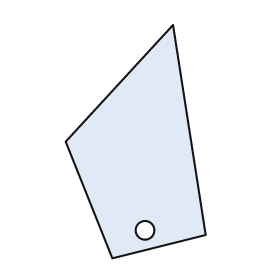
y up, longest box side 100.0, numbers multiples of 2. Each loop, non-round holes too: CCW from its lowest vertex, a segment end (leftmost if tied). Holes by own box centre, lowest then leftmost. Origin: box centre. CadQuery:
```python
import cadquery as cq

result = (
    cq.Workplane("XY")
    .moveTo(-10.0, -50.0)
    .lineTo(30.0, -40.0)
    .lineTo(16.0, 50.0)
    .lineTo(-30.0, 0.0)
    .close()
    .moveTo(4.0, -38.0)
    .circle(4.0)
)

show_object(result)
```